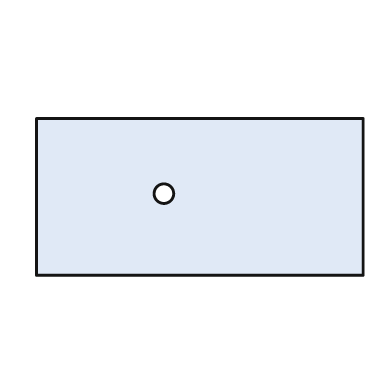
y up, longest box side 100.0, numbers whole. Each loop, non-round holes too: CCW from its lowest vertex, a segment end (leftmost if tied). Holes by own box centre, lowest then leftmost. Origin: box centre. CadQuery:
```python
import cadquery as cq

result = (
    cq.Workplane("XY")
    .moveTo(-50.0, -24.0)
    .lineTo(50.0, -24.0)
    .lineTo(50.0, 24.0)
    .lineTo(-50.0, 24.0)
    .close()
    .moveTo(-11.0, 1.0)
    .circle(3.0)
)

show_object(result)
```